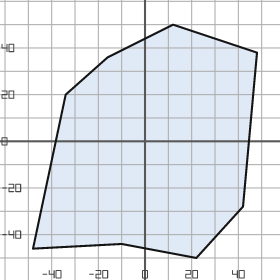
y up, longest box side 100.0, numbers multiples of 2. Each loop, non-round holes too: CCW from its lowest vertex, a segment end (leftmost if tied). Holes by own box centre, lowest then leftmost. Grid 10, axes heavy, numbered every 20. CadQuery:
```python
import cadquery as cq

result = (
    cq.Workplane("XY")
    .moveTo(22.0, -50.0)
    .lineTo(42.0, -28.0)
    .lineTo(48.0, 38.0)
    .lineTo(12.0, 50.0)
    .lineTo(-16.0, 36.0)
    .lineTo(-34.0, 20.0)
    .lineTo(-48.0, -46.0)
    .lineTo(-10.0, -44.0)
    .close()
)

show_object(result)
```